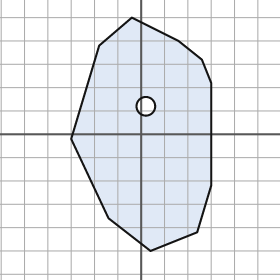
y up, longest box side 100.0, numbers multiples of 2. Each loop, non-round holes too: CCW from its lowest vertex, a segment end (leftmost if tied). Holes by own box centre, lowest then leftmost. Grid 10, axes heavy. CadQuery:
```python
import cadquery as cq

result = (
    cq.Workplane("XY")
    .moveTo(4.0, -50.0)
    .lineTo(24.0, -42.0)
    .lineTo(30.0, -22.0)
    .lineTo(30.0, 22.0)
    .lineTo(26.0, 32.0)
    .lineTo(16.0, 40.0)
    .lineTo(-4.0, 50.0)
    .lineTo(-18.0, 38.0)
    .lineTo(-30.0, -2.0)
    .lineTo(-14.0, -36.0)
    .close()
    .moveTo(2.0, 12.0)
    .circle(4.0)
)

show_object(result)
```